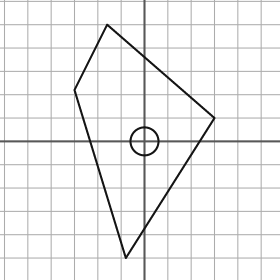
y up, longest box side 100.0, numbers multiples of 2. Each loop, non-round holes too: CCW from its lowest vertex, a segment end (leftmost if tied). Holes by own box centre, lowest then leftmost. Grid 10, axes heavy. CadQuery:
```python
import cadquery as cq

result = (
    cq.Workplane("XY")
    .moveTo(-8.0, -50.0)
    .lineTo(30.0, 10.0)
    .lineTo(-16.0, 50.0)
    .lineTo(-30.0, 22.0)
    .close()
    .moveTo(0.0, 0.0)
    .circle(6.0)
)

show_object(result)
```